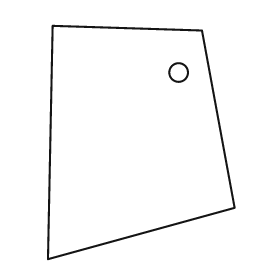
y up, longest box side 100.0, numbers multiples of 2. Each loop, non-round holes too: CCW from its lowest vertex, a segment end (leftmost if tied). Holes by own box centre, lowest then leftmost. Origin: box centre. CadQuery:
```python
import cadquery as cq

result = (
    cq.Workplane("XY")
    .moveTo(-40.0, -50.0)
    .lineTo(40.0, -28.0)
    .lineTo(26.0, 48.0)
    .lineTo(-38.0, 50.0)
    .close()
    .moveTo(16.0, 30.0)
    .circle(4.0)
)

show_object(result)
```